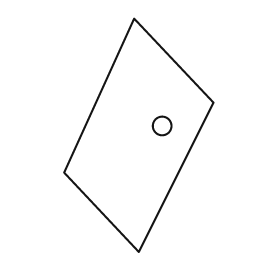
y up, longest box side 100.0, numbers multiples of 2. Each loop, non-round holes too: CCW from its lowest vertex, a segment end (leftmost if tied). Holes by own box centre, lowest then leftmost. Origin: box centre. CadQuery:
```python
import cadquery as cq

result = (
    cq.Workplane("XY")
    .moveTo(0.0, -50.0)
    .lineTo(32.0, 14.0)
    .lineTo(-2.0, 50.0)
    .lineTo(-32.0, -16.0)
    .close()
    .moveTo(10.0, 4.0)
    .circle(4.0)
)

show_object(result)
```